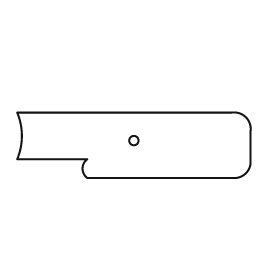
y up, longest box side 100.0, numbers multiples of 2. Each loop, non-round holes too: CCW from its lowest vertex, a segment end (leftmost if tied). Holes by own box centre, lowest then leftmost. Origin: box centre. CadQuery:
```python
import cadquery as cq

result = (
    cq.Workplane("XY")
    .moveTo(-20.0, -14.0)
    .lineTo(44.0, -14.0)
    .threePointArc((48.0, -12.0), (50.0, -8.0))
    .lineTo(50.0, 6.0)
    .threePointArc((48.0, 12.0), (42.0, 14.0))
    .lineTo(-50.0, 14.0)
    .threePointArc((-48.0, 4.0), (-50.0, -6.0))
    .lineTo(-20.0, -6.0)
    .threePointArc((-22.0, -10.0), (-20.0, -14.0))
    .close()
    .moveTo(0.0, 2.0)
    .circle(2.0)
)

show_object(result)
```